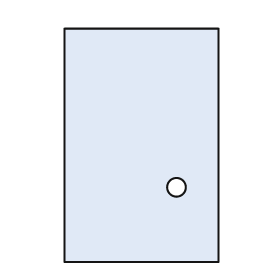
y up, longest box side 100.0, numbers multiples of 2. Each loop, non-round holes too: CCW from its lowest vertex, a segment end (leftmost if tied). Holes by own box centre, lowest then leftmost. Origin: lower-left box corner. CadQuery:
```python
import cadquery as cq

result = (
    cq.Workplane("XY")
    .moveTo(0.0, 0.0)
    .lineTo(66.0, 0.0)
    .lineTo(66.0, 100.0)
    .lineTo(0.0, 100.0)
    .close()
    .moveTo(48.0, 32.0)
    .circle(4.0)
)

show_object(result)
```